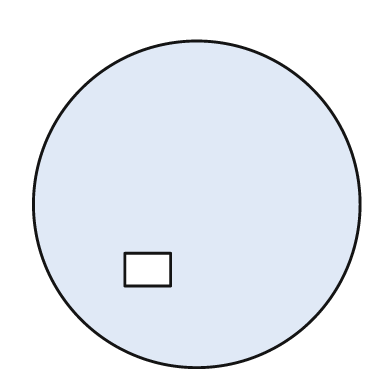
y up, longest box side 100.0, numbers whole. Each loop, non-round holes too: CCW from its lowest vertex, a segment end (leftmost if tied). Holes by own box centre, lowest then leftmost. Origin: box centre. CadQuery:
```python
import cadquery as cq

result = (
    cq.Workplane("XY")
    .moveTo(0.0, 0.0)
    .circle(50.0)
    .moveTo(-22.0, -25.0)
    .lineTo(-8.0, -25.0)
    .lineTo(-8.0, -15.0)
    .lineTo(-22.0, -15.0)
    .close()
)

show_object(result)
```